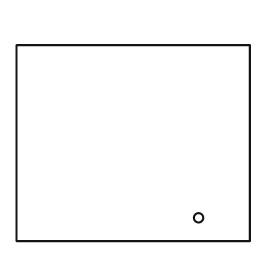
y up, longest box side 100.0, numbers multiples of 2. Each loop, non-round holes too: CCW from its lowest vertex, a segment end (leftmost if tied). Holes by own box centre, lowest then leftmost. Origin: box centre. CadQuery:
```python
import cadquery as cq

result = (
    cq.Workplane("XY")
    .moveTo(-50.0, -42.0)
    .lineTo(50.0, -42.0)
    .lineTo(50.0, 42.0)
    .lineTo(-50.0, 42.0)
    .close()
    .moveTo(28.0, -32.0)
    .circle(2.0)
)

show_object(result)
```